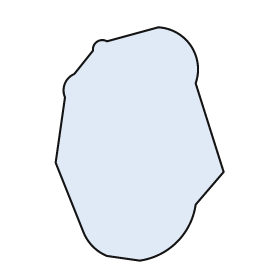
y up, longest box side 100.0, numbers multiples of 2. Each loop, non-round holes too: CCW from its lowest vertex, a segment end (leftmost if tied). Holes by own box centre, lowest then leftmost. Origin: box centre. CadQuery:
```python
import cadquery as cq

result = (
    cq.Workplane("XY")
    .moveTo(0.0, -50.0)
    .threePointArc((16.0, -42.0), (24.0, -26.0))
    .lineTo(36.0, -12.0)
    .lineTo(24.0, 26.0)
    .threePointArc((22.0, 42.0), (8.0, 50.0))
    .lineTo(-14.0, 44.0)
    .threePointArc((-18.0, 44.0), (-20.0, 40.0))
    .lineTo(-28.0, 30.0)
    .threePointArc((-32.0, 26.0), (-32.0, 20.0))
    .lineTo(-36.0, -8.0)
    .lineTo(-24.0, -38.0)
    .threePointArc((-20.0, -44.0), (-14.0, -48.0))
    .close()
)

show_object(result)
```